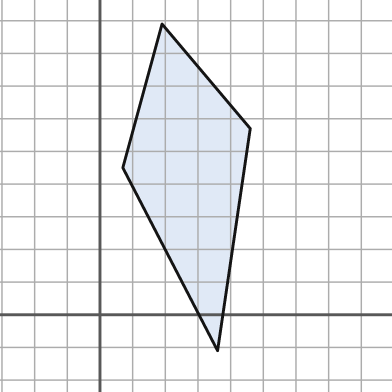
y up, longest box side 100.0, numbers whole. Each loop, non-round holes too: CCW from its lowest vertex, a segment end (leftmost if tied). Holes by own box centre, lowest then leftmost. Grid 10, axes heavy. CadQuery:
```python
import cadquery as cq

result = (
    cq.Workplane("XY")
    .moveTo(36.0, -11.0)
    .lineTo(46.0, 57.0)
    .lineTo(19.0, 89.0)
    .lineTo(7.0, 45.0)
    .close()
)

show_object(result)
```